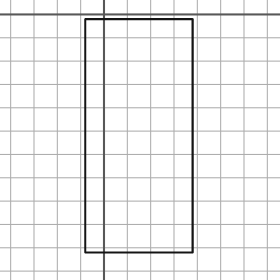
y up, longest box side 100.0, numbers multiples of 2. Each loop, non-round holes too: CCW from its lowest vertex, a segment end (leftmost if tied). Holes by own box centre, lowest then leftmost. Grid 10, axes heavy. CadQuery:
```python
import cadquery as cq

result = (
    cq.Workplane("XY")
    .moveTo(-8.0, -102.0)
    .lineTo(38.0, -102.0)
    .lineTo(38.0, -2.0)
    .lineTo(-8.0, -2.0)
    .close()
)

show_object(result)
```